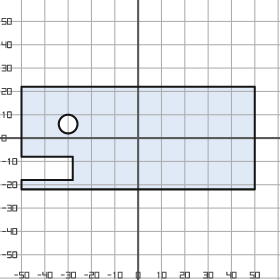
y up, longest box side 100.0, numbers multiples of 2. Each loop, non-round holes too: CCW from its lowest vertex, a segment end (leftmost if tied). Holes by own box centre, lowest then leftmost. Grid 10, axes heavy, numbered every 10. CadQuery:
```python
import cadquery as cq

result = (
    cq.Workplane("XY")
    .moveTo(-50.0, -22.0)
    .lineTo(50.0, -22.0)
    .lineTo(50.0, 22.0)
    .lineTo(-50.0, 22.0)
    .lineTo(-50.0, -8.0)
    .lineTo(-28.0, -8.0)
    .lineTo(-28.0, -18.0)
    .lineTo(-50.0, -18.0)
    .close()
    .moveTo(-30.0, 6.0)
    .circle(4.0)
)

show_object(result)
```